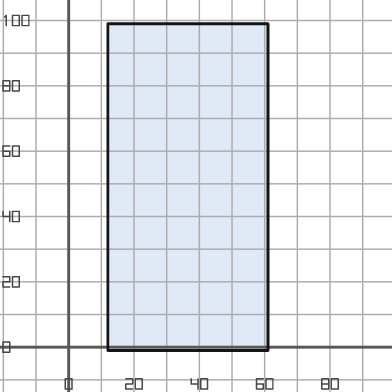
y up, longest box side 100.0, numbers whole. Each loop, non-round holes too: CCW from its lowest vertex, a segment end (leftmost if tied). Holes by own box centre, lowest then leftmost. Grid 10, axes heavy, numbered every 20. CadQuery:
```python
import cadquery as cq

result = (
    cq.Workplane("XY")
    .moveTo(12.0, -1.0)
    .lineTo(61.0, -1.0)
    .lineTo(61.0, 99.0)
    .lineTo(12.0, 99.0)
    .close()
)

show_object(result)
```